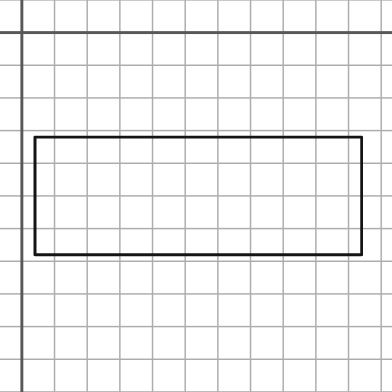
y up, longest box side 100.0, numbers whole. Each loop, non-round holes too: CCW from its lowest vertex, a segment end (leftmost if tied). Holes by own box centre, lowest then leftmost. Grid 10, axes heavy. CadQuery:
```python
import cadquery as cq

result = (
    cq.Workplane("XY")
    .moveTo(4.0, -68.0)
    .lineTo(104.0, -68.0)
    .lineTo(104.0, -32.0)
    .lineTo(4.0, -32.0)
    .close()
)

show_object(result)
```